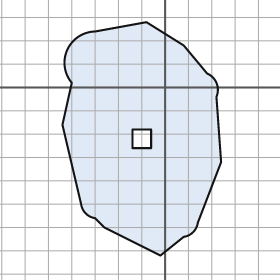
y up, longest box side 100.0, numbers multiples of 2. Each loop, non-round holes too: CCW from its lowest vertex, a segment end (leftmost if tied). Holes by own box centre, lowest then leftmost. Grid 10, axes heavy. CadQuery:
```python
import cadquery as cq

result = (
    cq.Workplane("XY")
    .moveTo(-2.0, -72.0)
    .lineTo(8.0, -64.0)
    .threePointArc((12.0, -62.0), (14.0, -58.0))
    .lineTo(24.0, -32.0)
    .lineTo(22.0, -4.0)
    .threePointArc((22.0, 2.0), (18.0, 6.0))
    .lineTo(8.0, 18.0)
    .lineTo(-8.0, 28.0)
    .lineTo(-30.0, 24.0)
    .threePointArc((-42.0, 16.0), (-40.0, 2.0))
    .lineTo(-44.0, -16.0)
    .lineTo(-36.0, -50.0)
    .threePointArc((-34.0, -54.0), (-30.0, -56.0))
    .lineTo(-26.0, -60.0)
    .close()
    .moveTo(-14.0, -26.0)
    .lineTo(-6.0, -26.0)
    .lineTo(-6.0, -18.0)
    .lineTo(-14.0, -18.0)
    .close()
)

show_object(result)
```